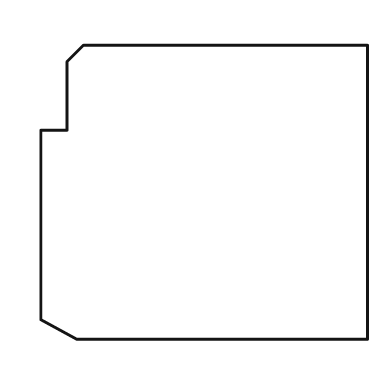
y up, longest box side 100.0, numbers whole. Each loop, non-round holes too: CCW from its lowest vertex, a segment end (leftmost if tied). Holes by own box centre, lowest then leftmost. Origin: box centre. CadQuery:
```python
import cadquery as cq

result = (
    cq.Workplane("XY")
    .moveTo(-39.0, -45.0)
    .lineTo(50.0, -45.0)
    .lineTo(50.0, 45.0)
    .lineTo(-37.0, 45.0)
    .lineTo(-42.0, 40.0)
    .lineTo(-42.0, 19.0)
    .lineTo(-50.0, 19.0)
    .lineTo(-50.0, -39.0)
    .close()
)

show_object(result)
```